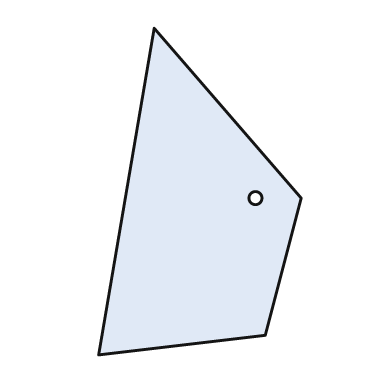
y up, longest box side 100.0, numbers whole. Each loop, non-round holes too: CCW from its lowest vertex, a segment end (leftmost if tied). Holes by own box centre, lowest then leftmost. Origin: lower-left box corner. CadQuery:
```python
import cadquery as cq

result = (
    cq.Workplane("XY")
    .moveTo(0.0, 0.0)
    .lineTo(51.0, 6.0)
    .lineTo(62.0, 48.0)
    .lineTo(17.0, 100.0)
    .close()
    .moveTo(48.0, 48.0)
    .circle(2.0)
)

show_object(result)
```